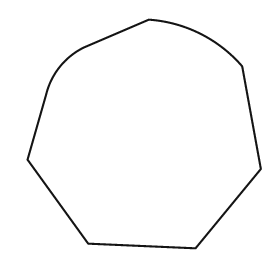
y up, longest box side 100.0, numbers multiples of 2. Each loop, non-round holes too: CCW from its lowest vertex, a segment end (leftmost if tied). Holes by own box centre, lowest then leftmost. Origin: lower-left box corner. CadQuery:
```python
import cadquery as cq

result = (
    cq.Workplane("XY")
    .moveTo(72.0, 0.0)
    .lineTo(100.0, 34.0)
    .lineTo(92.0, 78.0)
    .threePointArc((74.0, 92.0), (52.0, 98.0))
    .lineTo(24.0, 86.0)
    .threePointArc((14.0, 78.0), (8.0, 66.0))
    .lineTo(0.0, 38.0)
    .lineTo(26.0, 2.0)
    .close()
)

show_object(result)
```